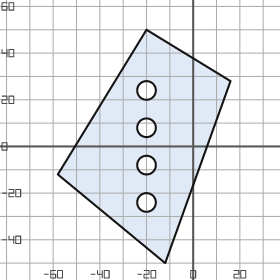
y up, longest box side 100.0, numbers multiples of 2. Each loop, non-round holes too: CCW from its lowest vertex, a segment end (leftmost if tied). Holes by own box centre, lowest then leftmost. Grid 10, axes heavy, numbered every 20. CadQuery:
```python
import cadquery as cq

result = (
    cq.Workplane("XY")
    .moveTo(-12.0, -50.0)
    .lineTo(16.0, 28.0)
    .lineTo(-20.0, 50.0)
    .lineTo(-58.0, -12.0)
    .close()
    .moveTo(-20.0, -24.0)
    .circle(4.0)
    .moveTo(-20.0, -8.0)
    .circle(4.0)
    .moveTo(-20.0, 8.0)
    .circle(4.0)
    .moveTo(-20.0, 24.0)
    .circle(4.0)
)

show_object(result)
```